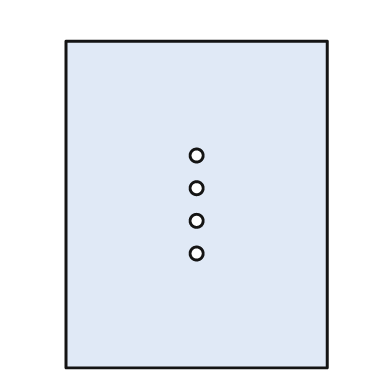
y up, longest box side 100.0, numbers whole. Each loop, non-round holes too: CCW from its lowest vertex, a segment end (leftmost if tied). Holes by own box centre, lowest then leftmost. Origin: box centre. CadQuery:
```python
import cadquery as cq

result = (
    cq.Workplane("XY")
    .moveTo(-40.0, -50.0)
    .lineTo(40.0, -50.0)
    .lineTo(40.0, 50.0)
    .lineTo(-40.0, 50.0)
    .close()
    .moveTo(0.0, -15.0)
    .circle(2.0)
    .moveTo(0.0, -5.0)
    .circle(2.0)
    .moveTo(0.0, 5.0)
    .circle(2.0)
    .moveTo(0.0, 15.0)
    .circle(2.0)
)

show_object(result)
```